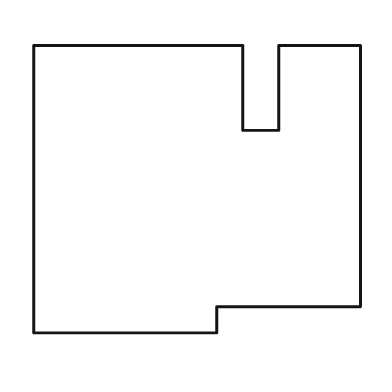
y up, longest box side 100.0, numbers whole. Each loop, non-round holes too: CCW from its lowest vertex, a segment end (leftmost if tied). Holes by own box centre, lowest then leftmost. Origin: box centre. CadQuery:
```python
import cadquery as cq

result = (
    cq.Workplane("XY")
    .moveTo(-50.0, -44.0)
    .lineTo(6.0, -44.0)
    .lineTo(6.0, -36.0)
    .lineTo(50.0, -36.0)
    .lineTo(50.0, 44.0)
    .lineTo(25.0, 44.0)
    .lineTo(25.0, 18.0)
    .lineTo(14.0, 18.0)
    .lineTo(14.0, 44.0)
    .lineTo(-50.0, 44.0)
    .close()
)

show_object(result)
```